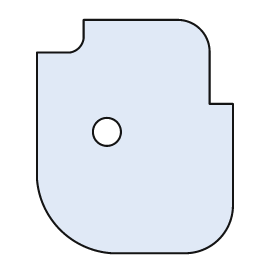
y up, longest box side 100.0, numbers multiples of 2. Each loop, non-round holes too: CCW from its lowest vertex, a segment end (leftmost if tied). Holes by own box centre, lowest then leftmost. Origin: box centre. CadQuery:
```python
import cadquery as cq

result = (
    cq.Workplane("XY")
    .moveTo(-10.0, -50.0)
    .lineTo(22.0, -50.0)
    .threePointArc((36.0, -44.0), (42.0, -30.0))
    .lineTo(42.0, 14.0)
    .lineTo(32.0, 14.0)
    .lineTo(32.0, 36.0)
    .threePointArc((28.0, 46.0), (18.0, 50.0))
    .lineTo(-22.0, 50.0)
    .lineTo(-22.0, 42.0)
    .threePointArc((-24.0, 38.0), (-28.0, 36.0))
    .lineTo(-42.0, 36.0)
    .lineTo(-42.0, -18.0)
    .threePointArc((-32.0, -40.0), (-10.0, -50.0))
    .close()
    .moveTo(-12.0, 2.0)
    .circle(6.0)
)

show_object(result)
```